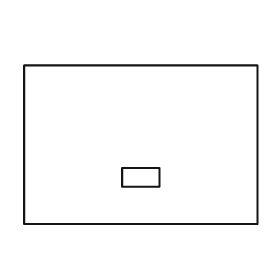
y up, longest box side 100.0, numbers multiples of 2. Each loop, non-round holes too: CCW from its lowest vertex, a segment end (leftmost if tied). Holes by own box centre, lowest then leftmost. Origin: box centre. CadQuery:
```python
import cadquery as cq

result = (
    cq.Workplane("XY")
    .moveTo(-50.0, -34.0)
    .lineTo(50.0, -34.0)
    .lineTo(50.0, 34.0)
    .lineTo(-50.0, 34.0)
    .close()
    .moveTo(-8.0, -18.0)
    .lineTo(8.0, -18.0)
    .lineTo(8.0, -10.0)
    .lineTo(-8.0, -10.0)
    .close()
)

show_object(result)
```